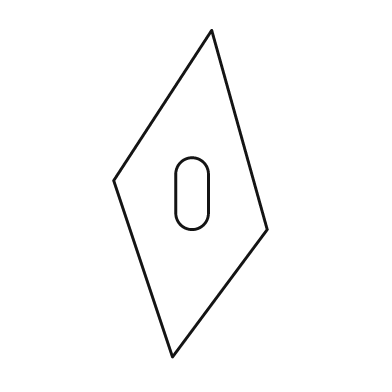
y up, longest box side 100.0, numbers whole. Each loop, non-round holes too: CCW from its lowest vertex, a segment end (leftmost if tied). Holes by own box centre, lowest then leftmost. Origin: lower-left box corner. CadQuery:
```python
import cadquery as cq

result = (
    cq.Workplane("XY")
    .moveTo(18.0, 0.0)
    .lineTo(47.0, 39.0)
    .lineTo(30.0, 100.0)
    .lineTo(0.0, 54.0)
    .close()
    .moveTo(19.0, 44.0)
    .threePointArc((24.0, 39.0), (29.0, 44.0))
    .lineTo(29.0, 56.0)
    .threePointArc((24.0, 61.0), (19.0, 56.0))
    .close()
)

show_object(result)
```